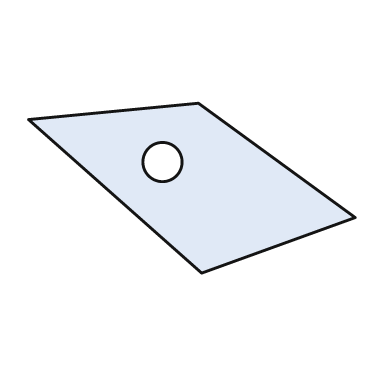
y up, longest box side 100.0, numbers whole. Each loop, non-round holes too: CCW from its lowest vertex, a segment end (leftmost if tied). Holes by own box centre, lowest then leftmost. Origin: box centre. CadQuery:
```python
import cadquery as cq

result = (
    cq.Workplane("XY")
    .moveTo(3.0, -26.0)
    .lineTo(50.0, -9.0)
    .lineTo(2.0, 26.0)
    .lineTo(-50.0, 21.0)
    .close()
    .moveTo(-9.0, 8.0)
    .circle(6.0)
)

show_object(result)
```